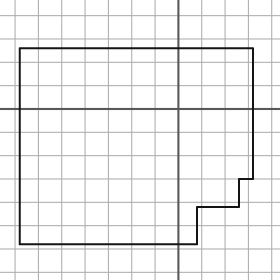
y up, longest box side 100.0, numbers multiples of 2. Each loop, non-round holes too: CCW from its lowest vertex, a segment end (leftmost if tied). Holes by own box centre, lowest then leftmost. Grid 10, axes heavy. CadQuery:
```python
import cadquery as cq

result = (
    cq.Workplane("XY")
    .moveTo(-68.0, -58.0)
    .lineTo(8.0, -58.0)
    .lineTo(8.0, -42.0)
    .lineTo(26.0, -42.0)
    .lineTo(26.0, -30.0)
    .lineTo(32.0, -30.0)
    .lineTo(32.0, 26.0)
    .lineTo(-68.0, 26.0)
    .close()
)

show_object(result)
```